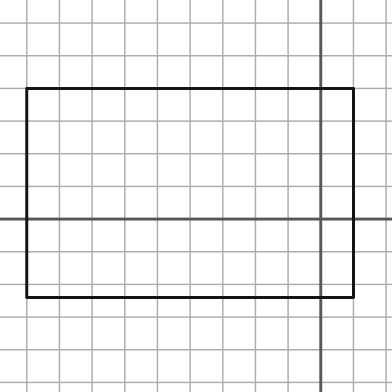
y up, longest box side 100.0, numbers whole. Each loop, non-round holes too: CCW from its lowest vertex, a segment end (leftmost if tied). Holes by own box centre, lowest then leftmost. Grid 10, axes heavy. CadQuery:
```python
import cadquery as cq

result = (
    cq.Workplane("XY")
    .moveTo(-90.0, -24.0)
    .lineTo(10.0, -24.0)
    .lineTo(10.0, 40.0)
    .lineTo(-90.0, 40.0)
    .close()
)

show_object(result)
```